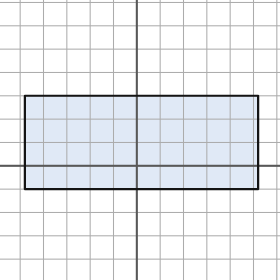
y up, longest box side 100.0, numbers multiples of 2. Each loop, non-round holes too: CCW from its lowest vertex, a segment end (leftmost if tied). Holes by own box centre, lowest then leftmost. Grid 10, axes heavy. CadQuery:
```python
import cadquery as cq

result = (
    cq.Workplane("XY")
    .moveTo(-48.0, -10.0)
    .lineTo(52.0, -10.0)
    .lineTo(52.0, 30.0)
    .lineTo(-48.0, 30.0)
    .close()
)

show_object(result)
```